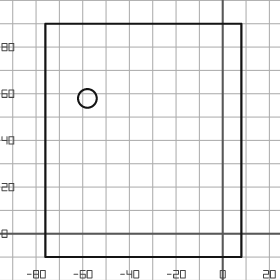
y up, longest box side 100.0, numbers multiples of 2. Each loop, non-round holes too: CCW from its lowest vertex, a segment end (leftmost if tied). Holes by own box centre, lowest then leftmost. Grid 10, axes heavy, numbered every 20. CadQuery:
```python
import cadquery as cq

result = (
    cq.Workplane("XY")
    .moveTo(-76.0, -10.0)
    .lineTo(8.0, -10.0)
    .lineTo(8.0, 90.0)
    .lineTo(-76.0, 90.0)
    .close()
    .moveTo(-58.0, 58.0)
    .circle(4.0)
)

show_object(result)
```